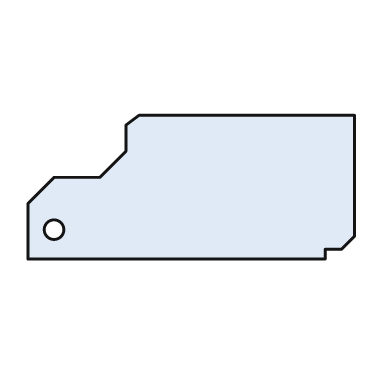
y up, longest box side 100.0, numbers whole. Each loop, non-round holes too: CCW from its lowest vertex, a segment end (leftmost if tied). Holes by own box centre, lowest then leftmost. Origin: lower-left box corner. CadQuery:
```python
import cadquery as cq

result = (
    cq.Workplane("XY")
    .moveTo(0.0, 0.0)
    .lineTo(91.0, 0.0)
    .lineTo(91.0, 3.0)
    .lineTo(96.0, 3.0)
    .lineTo(100.0, 7.0)
    .lineTo(100.0, 44.0)
    .lineTo(34.0, 44.0)
    .lineTo(30.0, 41.0)
    .lineTo(30.0, 33.0)
    .lineTo(22.0, 25.0)
    .lineTo(8.0, 25.0)
    .lineTo(0.0, 17.0)
    .close()
    .moveTo(8.0, 9.0)
    .circle(3.0)
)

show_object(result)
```